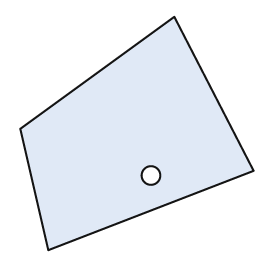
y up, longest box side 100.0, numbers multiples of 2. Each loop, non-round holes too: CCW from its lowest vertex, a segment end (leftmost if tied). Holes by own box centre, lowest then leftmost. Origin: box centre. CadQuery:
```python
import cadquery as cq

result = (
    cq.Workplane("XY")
    .moveTo(-38.0, -50.0)
    .lineTo(50.0, -16.0)
    .lineTo(16.0, 50.0)
    .lineTo(-50.0, 2.0)
    .close()
    .moveTo(6.0, -18.0)
    .circle(4.0)
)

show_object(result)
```